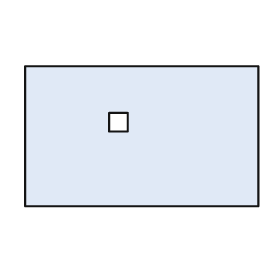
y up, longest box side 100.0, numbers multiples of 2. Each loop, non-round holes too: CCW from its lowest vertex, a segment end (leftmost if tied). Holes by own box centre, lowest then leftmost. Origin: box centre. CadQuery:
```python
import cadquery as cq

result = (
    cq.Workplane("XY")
    .moveTo(-50.0, -30.0)
    .lineTo(50.0, -30.0)
    .lineTo(50.0, 30.0)
    .lineTo(-50.0, 30.0)
    .close()
    .moveTo(-14.0, 2.0)
    .lineTo(-6.0, 2.0)
    .lineTo(-6.0, 10.0)
    .lineTo(-14.0, 10.0)
    .close()
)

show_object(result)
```